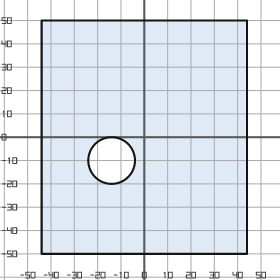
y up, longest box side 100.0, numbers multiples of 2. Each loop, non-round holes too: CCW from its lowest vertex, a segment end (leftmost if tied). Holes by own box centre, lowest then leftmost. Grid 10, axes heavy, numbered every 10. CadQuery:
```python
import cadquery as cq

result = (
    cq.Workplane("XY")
    .moveTo(-44.0, -50.0)
    .lineTo(44.0, -50.0)
    .lineTo(44.0, 50.0)
    .lineTo(-44.0, 50.0)
    .close()
    .moveTo(-14.0, -10.0)
    .circle(10.0)
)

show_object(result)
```